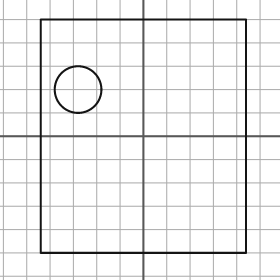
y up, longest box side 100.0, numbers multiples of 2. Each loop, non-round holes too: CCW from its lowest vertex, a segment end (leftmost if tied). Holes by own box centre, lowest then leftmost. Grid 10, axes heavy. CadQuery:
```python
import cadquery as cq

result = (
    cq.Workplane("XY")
    .moveTo(-44.0, -50.0)
    .lineTo(44.0, -50.0)
    .lineTo(44.0, 50.0)
    .lineTo(-44.0, 50.0)
    .close()
    .moveTo(-28.0, 20.0)
    .circle(10.0)
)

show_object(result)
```